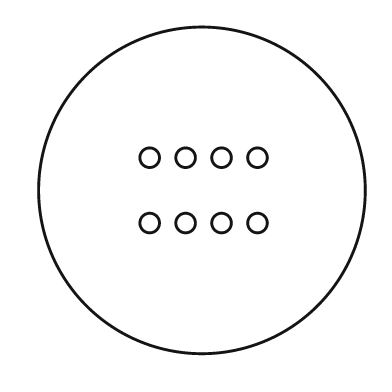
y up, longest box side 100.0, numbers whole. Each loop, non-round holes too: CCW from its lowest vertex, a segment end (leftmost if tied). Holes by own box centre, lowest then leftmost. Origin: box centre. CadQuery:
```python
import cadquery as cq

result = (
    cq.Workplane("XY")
    .moveTo(0.0, 0.0)
    .circle(50.0)
    .moveTo(-16.0, -10.0)
    .circle(3.0)
    .moveTo(-5.0, -10.0)
    .circle(3.0)
    .moveTo(6.0, -10.0)
    .circle(3.0)
    .moveTo(17.0, -10.0)
    .circle(3.0)
    .moveTo(-16.0, 10.0)
    .circle(3.0)
    .moveTo(-5.0, 10.0)
    .circle(3.0)
    .moveTo(6.0, 10.0)
    .circle(3.0)
    .moveTo(17.0, 10.0)
    .circle(3.0)
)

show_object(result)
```